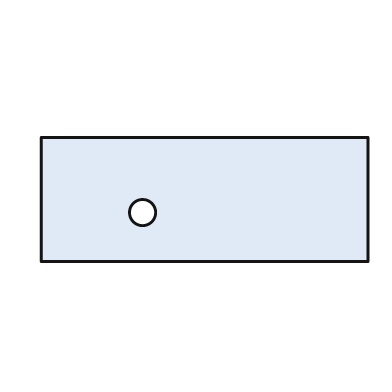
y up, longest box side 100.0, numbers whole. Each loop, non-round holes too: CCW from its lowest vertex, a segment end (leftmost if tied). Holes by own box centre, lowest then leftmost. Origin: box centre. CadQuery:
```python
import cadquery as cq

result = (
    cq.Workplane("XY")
    .moveTo(-50.0, -19.0)
    .lineTo(50.0, -19.0)
    .lineTo(50.0, 19.0)
    .lineTo(-50.0, 19.0)
    .close()
    .moveTo(-19.0, -4.0)
    .circle(4.0)
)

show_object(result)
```